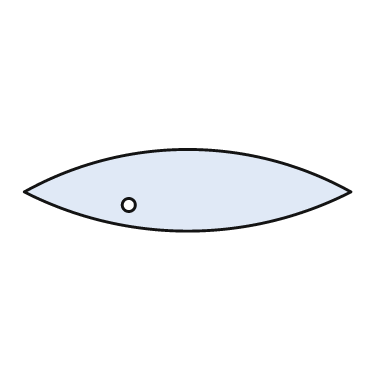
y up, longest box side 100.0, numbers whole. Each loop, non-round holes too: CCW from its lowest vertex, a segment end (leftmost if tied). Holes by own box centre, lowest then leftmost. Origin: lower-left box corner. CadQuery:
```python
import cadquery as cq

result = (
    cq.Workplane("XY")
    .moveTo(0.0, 12.0)
    .threePointArc((50.0, 0.0), (100.0, 12.0))
    .threePointArc((50.0, 25.0), (0.0, 12.0))
    .close()
    .moveTo(32.0, 8.0)
    .circle(2.0)
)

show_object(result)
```